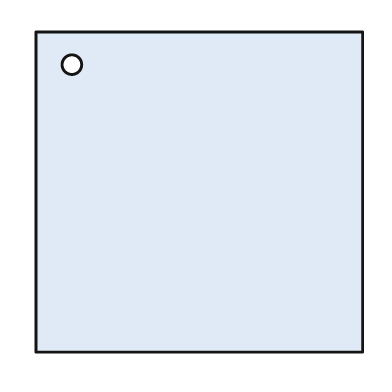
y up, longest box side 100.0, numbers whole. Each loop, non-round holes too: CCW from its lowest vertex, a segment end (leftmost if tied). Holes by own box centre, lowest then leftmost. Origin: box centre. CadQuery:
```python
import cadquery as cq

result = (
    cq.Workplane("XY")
    .moveTo(-50.0, -49.0)
    .lineTo(50.0, -49.0)
    .lineTo(50.0, 49.0)
    .lineTo(-50.0, 49.0)
    .close()
    .moveTo(-39.0, 39.0)
    .circle(3.0)
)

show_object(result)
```